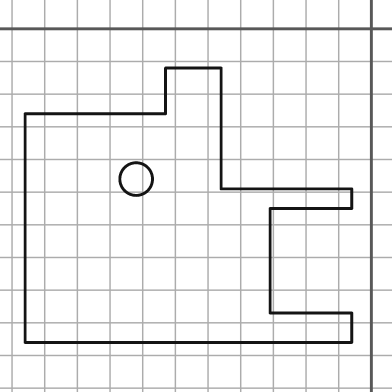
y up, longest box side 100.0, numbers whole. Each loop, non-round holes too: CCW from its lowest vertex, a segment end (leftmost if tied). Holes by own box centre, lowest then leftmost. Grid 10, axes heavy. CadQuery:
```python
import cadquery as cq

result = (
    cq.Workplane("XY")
    .moveTo(-106.0, -96.0)
    .lineTo(-6.0, -96.0)
    .lineTo(-6.0, -87.0)
    .lineTo(-31.0, -87.0)
    .lineTo(-31.0, -55.0)
    .lineTo(-6.0, -55.0)
    .lineTo(-6.0, -49.0)
    .lineTo(-46.0, -49.0)
    .lineTo(-46.0, -12.0)
    .lineTo(-63.0, -12.0)
    .lineTo(-63.0, -26.0)
    .lineTo(-106.0, -26.0)
    .close()
    .moveTo(-72.0, -46.0)
    .circle(5.0)
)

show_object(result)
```